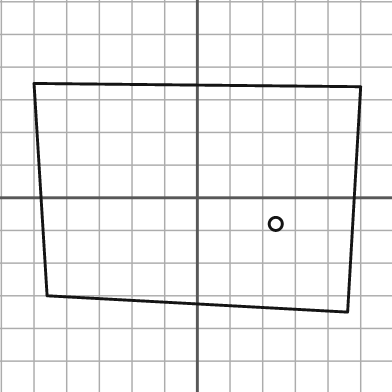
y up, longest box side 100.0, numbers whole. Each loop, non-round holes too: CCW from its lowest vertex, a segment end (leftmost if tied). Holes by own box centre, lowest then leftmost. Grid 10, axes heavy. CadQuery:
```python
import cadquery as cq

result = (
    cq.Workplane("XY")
    .moveTo(46.0, -35.0)
    .lineTo(50.0, 34.0)
    .lineTo(-50.0, 35.0)
    .lineTo(-46.0, -30.0)
    .close()
    .moveTo(24.0, -8.0)
    .circle(2.0)
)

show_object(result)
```